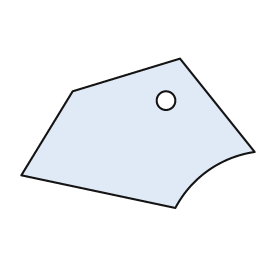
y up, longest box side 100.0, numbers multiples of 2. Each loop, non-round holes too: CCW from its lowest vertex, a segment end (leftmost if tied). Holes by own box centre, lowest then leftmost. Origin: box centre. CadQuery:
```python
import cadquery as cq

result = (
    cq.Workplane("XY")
    .moveTo(16.0, -32.0)
    .threePointArc((30.0, -16.0), (50.0, -8.0))
    .lineTo(18.0, 32.0)
    .lineTo(-28.0, 18.0)
    .lineTo(-50.0, -18.0)
    .close()
    .moveTo(12.0, 14.0)
    .circle(4.0)
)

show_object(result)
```